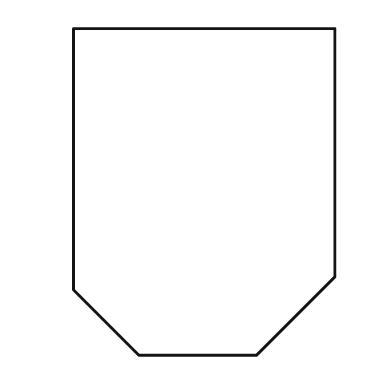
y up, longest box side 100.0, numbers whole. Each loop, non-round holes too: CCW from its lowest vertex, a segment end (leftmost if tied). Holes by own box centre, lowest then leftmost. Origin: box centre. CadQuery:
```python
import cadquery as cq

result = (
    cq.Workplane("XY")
    .moveTo(-20.0, -50.0)
    .lineTo(16.0, -50.0)
    .lineTo(40.0, -26.0)
    .lineTo(40.0, 50.0)
    .lineTo(-40.0, 50.0)
    .lineTo(-40.0, -30.0)
    .close()
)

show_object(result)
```